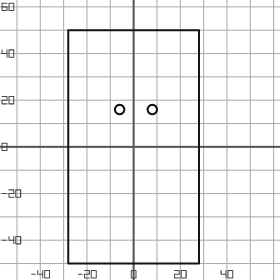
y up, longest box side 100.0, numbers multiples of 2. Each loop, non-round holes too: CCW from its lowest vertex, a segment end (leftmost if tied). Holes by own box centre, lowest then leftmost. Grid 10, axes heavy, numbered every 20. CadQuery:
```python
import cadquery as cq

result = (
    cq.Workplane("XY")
    .moveTo(-28.0, -50.0)
    .lineTo(28.0, -50.0)
    .lineTo(28.0, 50.0)
    .lineTo(-28.0, 50.0)
    .close()
    .moveTo(-6.0, 16.0)
    .circle(2.0)
    .moveTo(8.0, 16.0)
    .circle(2.0)
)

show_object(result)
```